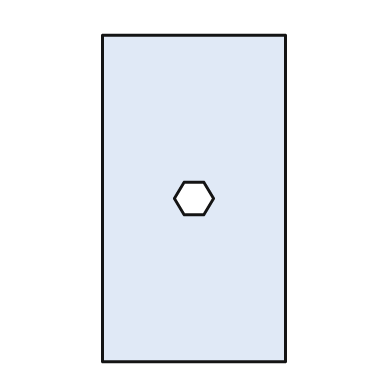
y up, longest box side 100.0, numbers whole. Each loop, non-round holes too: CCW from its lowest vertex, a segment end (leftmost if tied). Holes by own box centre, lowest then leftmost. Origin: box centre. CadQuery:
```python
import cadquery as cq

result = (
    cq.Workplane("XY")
    .moveTo(-28.0, -50.0)
    .lineTo(28.0, -50.0)
    .lineTo(28.0, 50.0)
    .lineTo(-28.0, 50.0)
    .close()
    .moveTo(-3.0, -5.0)
    .lineTo(3.0, -5.0)
    .lineTo(6.0, 0.0)
    .lineTo(3.0, 5.0)
    .lineTo(-3.0, 5.0)
    .lineTo(-6.0, 0.0)
    .close()
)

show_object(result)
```